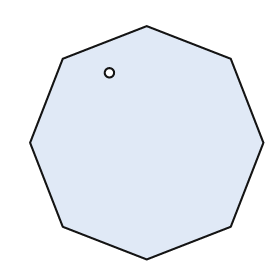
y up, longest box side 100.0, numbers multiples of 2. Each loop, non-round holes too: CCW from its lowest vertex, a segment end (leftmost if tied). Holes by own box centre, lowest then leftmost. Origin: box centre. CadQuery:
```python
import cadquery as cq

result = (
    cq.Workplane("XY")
    .moveTo(0.0, -50.0)
    .lineTo(36.0, -36.0)
    .lineTo(50.0, 0.0)
    .lineTo(36.0, 36.0)
    .lineTo(0.0, 50.0)
    .lineTo(-36.0, 36.0)
    .lineTo(-50.0, 0.0)
    .lineTo(-36.0, -36.0)
    .close()
    .moveTo(-16.0, 30.0)
    .circle(2.0)
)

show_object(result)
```